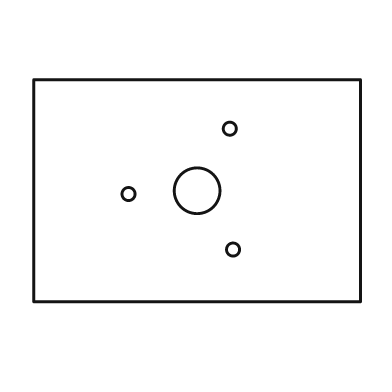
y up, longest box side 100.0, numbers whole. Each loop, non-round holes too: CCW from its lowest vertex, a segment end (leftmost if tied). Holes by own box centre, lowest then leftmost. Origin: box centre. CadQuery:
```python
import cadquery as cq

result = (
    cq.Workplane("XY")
    .moveTo(-50.0, -34.0)
    .lineTo(50.0, -34.0)
    .lineTo(50.0, 34.0)
    .lineTo(-50.0, 34.0)
    .close()
    .moveTo(11.0, -18.0)
    .circle(2.0)
    .moveTo(-21.0, -1.0)
    .circle(2.0)
    .moveTo(0.0, 0.0)
    .circle(7.0)
    .moveTo(10.0, 19.0)
    .circle(2.0)
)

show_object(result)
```